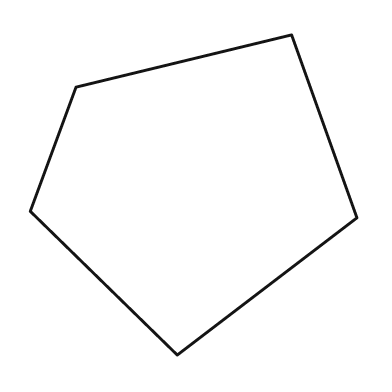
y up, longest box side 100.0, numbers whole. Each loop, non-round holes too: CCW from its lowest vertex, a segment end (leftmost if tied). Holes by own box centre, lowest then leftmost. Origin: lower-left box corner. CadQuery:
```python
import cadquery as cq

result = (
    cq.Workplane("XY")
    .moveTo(45.0, 0.0)
    .lineTo(100.0, 42.0)
    .lineTo(80.0, 98.0)
    .lineTo(14.0, 82.0)
    .lineTo(0.0, 44.0)
    .close()
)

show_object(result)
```